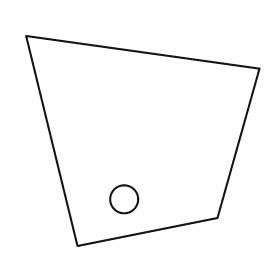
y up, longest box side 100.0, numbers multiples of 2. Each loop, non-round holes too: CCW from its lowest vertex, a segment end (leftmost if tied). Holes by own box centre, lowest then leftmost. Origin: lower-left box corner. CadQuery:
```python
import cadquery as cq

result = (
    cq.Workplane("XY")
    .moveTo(22.0, 0.0)
    .lineTo(82.0, 12.0)
    .lineTo(100.0, 76.0)
    .lineTo(0.0, 90.0)
    .close()
    .moveTo(42.0, 20.0)
    .circle(6.0)
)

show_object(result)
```